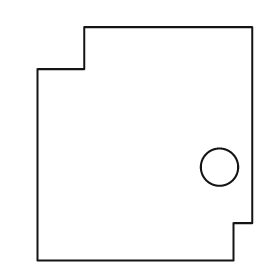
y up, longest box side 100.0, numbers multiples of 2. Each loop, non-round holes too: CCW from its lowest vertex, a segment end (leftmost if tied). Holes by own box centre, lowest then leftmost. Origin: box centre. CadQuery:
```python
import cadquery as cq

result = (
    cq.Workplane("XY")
    .moveTo(-46.0, -50.0)
    .lineTo(38.0, -50.0)
    .lineTo(38.0, -34.0)
    .lineTo(46.0, -34.0)
    .lineTo(46.0, 50.0)
    .lineTo(-26.0, 50.0)
    .lineTo(-26.0, 32.0)
    .lineTo(-46.0, 32.0)
    .close()
    .moveTo(32.0, -10.0)
    .circle(8.0)
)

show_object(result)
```